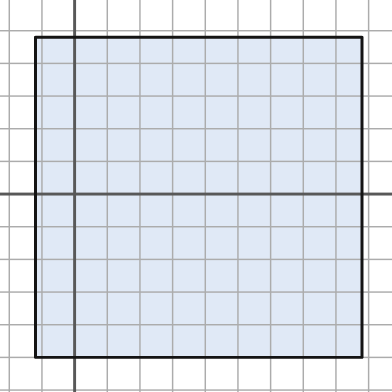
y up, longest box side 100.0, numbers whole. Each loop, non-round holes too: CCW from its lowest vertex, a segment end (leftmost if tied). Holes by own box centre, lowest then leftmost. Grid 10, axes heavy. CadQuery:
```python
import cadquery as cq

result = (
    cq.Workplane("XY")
    .moveTo(-12.0, -50.0)
    .lineTo(88.0, -50.0)
    .lineTo(88.0, 48.0)
    .lineTo(-12.0, 48.0)
    .close()
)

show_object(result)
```